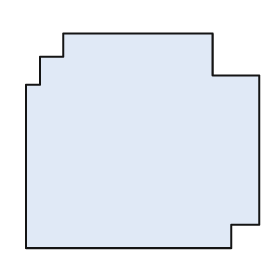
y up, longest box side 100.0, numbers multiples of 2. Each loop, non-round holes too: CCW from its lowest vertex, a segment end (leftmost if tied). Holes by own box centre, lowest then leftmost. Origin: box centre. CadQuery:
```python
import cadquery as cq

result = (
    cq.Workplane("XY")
    .moveTo(-50.0, -46.0)
    .lineTo(38.0, -46.0)
    .lineTo(38.0, -36.0)
    .lineTo(50.0, -36.0)
    .lineTo(50.0, 28.0)
    .lineTo(30.0, 28.0)
    .lineTo(30.0, 46.0)
    .lineTo(-34.0, 46.0)
    .lineTo(-34.0, 36.0)
    .lineTo(-44.0, 36.0)
    .lineTo(-44.0, 24.0)
    .lineTo(-50.0, 24.0)
    .close()
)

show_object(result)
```